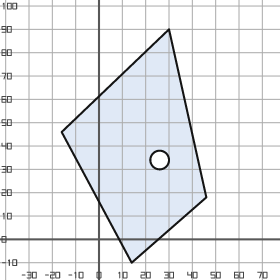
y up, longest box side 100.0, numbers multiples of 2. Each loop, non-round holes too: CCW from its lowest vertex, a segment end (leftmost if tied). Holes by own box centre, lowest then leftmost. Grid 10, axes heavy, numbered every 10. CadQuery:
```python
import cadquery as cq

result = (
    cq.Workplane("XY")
    .moveTo(14.0, -10.0)
    .lineTo(46.0, 18.0)
    .lineTo(30.0, 90.0)
    .lineTo(-16.0, 46.0)
    .close()
    .moveTo(26.0, 34.0)
    .circle(4.0)
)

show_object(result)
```